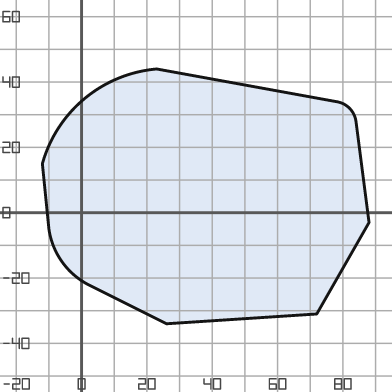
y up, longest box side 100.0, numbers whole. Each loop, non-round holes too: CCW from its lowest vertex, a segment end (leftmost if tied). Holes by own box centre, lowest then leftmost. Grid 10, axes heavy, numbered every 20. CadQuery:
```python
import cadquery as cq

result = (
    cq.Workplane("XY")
    .moveTo(26.0, -34.0)
    .lineTo(72.0, -31.0)
    .lineTo(88.0, -3.0)
    .lineTo(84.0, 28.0)
    .threePointArc((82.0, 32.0), (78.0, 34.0))
    .lineTo(23.0, 44.0)
    .threePointArc((1.0, 35.0), (-12.0, 15.0))
    .lineTo(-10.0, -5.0)
    .threePointArc((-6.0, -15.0), (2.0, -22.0))
    .close()
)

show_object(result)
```